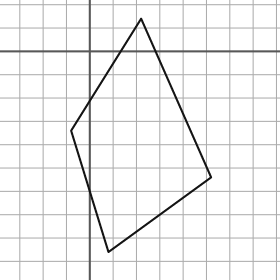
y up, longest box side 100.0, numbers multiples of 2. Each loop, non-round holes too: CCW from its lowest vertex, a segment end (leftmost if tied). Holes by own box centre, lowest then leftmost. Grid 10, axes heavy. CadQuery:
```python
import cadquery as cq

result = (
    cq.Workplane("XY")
    .moveTo(8.0, -86.0)
    .lineTo(52.0, -54.0)
    .lineTo(22.0, 14.0)
    .lineTo(-8.0, -34.0)
    .close()
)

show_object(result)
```